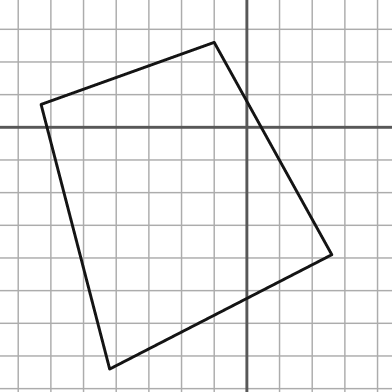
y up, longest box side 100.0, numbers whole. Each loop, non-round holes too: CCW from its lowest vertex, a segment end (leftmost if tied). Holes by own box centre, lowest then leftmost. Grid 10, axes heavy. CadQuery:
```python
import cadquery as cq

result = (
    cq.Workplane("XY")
    .moveTo(-42.0, -74.0)
    .lineTo(26.0, -39.0)
    .lineTo(-10.0, 26.0)
    .lineTo(-63.0, 7.0)
    .close()
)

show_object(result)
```